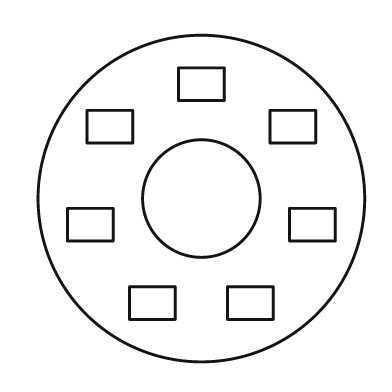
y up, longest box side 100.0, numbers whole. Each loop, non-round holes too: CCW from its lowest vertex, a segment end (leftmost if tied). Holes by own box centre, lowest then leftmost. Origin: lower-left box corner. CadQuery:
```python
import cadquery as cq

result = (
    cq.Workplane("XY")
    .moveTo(50.0, 50.0)
    .circle(50.0)
    .moveTo(28.0, 13.0)
    .lineTo(42.0, 13.0)
    .lineTo(42.0, 23.0)
    .lineTo(28.0, 23.0)
    .close()
    .moveTo(58.0, 13.0)
    .lineTo(72.0, 13.0)
    .lineTo(72.0, 23.0)
    .lineTo(58.0, 23.0)
    .close()
    .moveTo(9.0, 37.0)
    .lineTo(23.0, 37.0)
    .lineTo(23.0, 47.0)
    .lineTo(9.0, 47.0)
    .close()
    .moveTo(77.0, 37.0)
    .lineTo(91.0, 37.0)
    .lineTo(91.0, 47.0)
    .lineTo(77.0, 47.0)
    .close()
    .moveTo(50.0, 50.0)
    .circle(18.0)
    .moveTo(15.0, 67.0)
    .lineTo(29.0, 67.0)
    .lineTo(29.0, 77.0)
    .lineTo(15.0, 77.0)
    .close()
    .moveTo(71.0, 67.0)
    .lineTo(85.0, 67.0)
    .lineTo(85.0, 77.0)
    .lineTo(71.0, 77.0)
    .close()
    .moveTo(43.0, 80.0)
    .lineTo(57.0, 80.0)
    .lineTo(57.0, 90.0)
    .lineTo(43.0, 90.0)
    .close()
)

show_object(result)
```